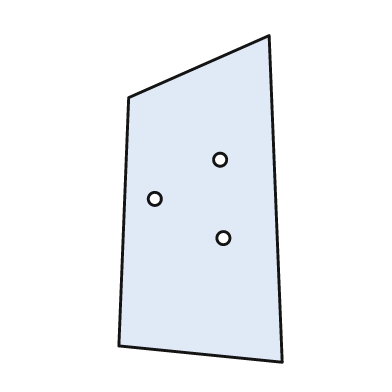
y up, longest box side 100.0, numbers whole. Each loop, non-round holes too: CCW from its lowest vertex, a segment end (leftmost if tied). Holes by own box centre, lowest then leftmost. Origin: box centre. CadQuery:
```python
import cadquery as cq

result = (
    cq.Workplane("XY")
    .moveTo(25.0, -50.0)
    .lineTo(21.0, 50.0)
    .lineTo(-22.0, 31.0)
    .lineTo(-25.0, -45.0)
    .close()
    .moveTo(7.0, -12.0)
    .circle(2.0)
    .moveTo(-14.0, 0.0)
    .circle(2.0)
    .moveTo(6.0, 12.0)
    .circle(2.0)
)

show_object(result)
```